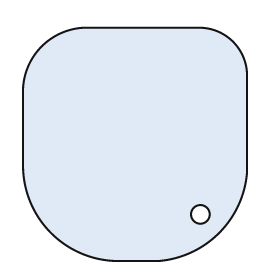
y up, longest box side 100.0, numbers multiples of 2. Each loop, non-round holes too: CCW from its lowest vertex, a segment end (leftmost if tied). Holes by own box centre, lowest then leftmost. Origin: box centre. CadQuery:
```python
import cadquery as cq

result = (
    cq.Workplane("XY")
    .moveTo(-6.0, -50.0)
    .lineTo(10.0, -50.0)
    .threePointArc((36.0, -38.0), (48.0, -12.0))
    .lineTo(48.0, 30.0)
    .threePointArc((42.0, 44.0), (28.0, 50.0))
    .lineTo(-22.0, 50.0)
    .threePointArc((-40.0, 42.0), (-48.0, 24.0))
    .lineTo(-48.0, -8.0)
    .threePointArc((-36.0, -38.0), (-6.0, -50.0))
    .close()
    .moveTo(28.0, -30.0)
    .circle(4.0)
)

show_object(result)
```